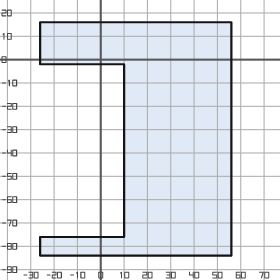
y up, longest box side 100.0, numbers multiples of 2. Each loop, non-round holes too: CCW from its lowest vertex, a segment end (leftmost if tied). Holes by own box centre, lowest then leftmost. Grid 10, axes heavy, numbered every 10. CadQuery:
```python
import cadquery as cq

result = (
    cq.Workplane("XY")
    .moveTo(-26.0, -84.0)
    .lineTo(56.0, -84.0)
    .lineTo(56.0, 16.0)
    .lineTo(-26.0, 16.0)
    .lineTo(-26.0, -2.0)
    .lineTo(10.0, -2.0)
    .lineTo(10.0, -76.0)
    .lineTo(-26.0, -76.0)
    .close()
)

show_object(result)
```